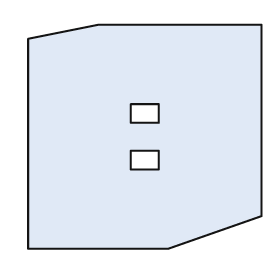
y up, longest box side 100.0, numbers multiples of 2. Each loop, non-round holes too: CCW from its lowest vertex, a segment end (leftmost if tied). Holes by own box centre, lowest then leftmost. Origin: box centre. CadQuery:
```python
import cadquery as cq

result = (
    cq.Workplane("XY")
    .moveTo(-50.0, -48.0)
    .lineTo(10.0, -48.0)
    .lineTo(50.0, -34.0)
    .lineTo(50.0, 48.0)
    .lineTo(-20.0, 48.0)
    .lineTo(-50.0, 42.0)
    .close()
    .moveTo(-6.0, -14.0)
    .lineTo(6.0, -14.0)
    .lineTo(6.0, -6.0)
    .lineTo(-6.0, -6.0)
    .close()
    .moveTo(-6.0, 6.0)
    .lineTo(6.0, 6.0)
    .lineTo(6.0, 14.0)
    .lineTo(-6.0, 14.0)
    .close()
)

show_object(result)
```